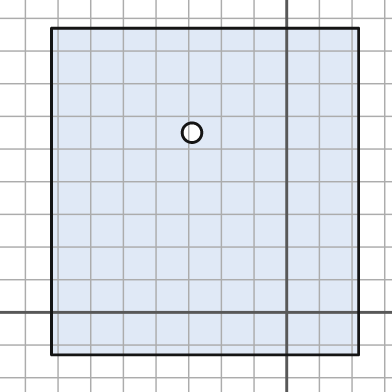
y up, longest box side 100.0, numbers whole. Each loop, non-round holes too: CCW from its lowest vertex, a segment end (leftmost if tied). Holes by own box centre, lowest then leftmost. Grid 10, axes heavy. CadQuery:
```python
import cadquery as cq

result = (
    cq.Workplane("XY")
    .moveTo(-72.0, -13.0)
    .lineTo(22.0, -13.0)
    .lineTo(22.0, 87.0)
    .lineTo(-72.0, 87.0)
    .close()
    .moveTo(-29.0, 55.0)
    .circle(3.0)
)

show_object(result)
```